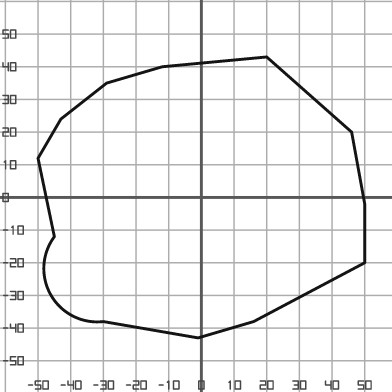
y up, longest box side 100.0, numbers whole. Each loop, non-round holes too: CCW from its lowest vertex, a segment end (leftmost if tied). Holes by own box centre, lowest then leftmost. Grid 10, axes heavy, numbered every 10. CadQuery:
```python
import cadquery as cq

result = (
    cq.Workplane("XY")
    .moveTo(-1.0, -43.0)
    .lineTo(16.0, -38.0)
    .lineTo(50.0, -20.0)
    .lineTo(50.0, -2.0)
    .lineTo(46.0, 20.0)
    .lineTo(20.0, 43.0)
    .lineTo(-12.0, 40.0)
    .lineTo(-29.0, 35.0)
    .lineTo(-43.0, 24.0)
    .lineTo(-50.0, 12.0)
    .lineTo(-45.0, -12.0)
    .threePointArc((-46.0, -30.0), (-30.0, -38.0))
    .close()
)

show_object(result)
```